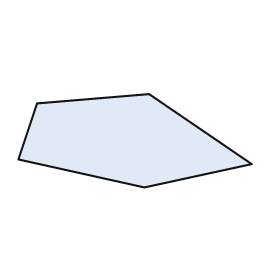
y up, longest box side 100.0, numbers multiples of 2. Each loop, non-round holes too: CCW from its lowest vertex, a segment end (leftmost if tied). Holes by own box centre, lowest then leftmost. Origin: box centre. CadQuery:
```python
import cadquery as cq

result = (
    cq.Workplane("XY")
    .moveTo(4.0, -20.0)
    .lineTo(50.0, -10.0)
    .lineTo(6.0, 20.0)
    .lineTo(-42.0, 16.0)
    .lineTo(-50.0, -8.0)
    .close()
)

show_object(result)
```